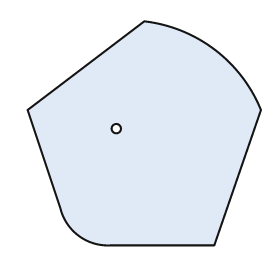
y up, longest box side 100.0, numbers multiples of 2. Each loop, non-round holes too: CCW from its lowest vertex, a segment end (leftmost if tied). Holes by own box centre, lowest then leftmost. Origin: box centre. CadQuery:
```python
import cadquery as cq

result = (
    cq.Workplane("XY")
    .moveTo(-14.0, -48.0)
    .lineTo(30.0, -48.0)
    .lineTo(50.0, 10.0)
    .threePointArc((30.0, 36.0), (0.0, 48.0))
    .lineTo(-50.0, 10.0)
    .lineTo(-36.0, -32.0)
    .threePointArc((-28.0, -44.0), (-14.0, -48.0))
    .close()
    .moveTo(-12.0, 2.0)
    .circle(2.0)
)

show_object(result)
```